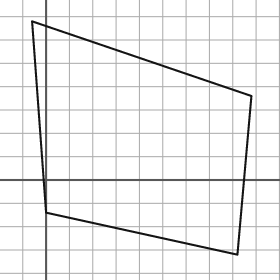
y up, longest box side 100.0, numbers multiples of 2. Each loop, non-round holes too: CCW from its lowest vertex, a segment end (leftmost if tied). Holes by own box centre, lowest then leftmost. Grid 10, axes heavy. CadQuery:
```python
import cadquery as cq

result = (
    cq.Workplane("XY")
    .moveTo(82.0, -32.0)
    .lineTo(88.0, 36.0)
    .lineTo(-6.0, 68.0)
    .lineTo(0.0, -14.0)
    .close()
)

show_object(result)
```